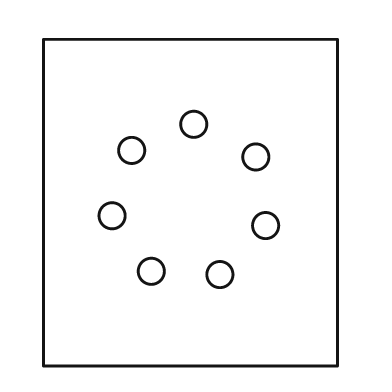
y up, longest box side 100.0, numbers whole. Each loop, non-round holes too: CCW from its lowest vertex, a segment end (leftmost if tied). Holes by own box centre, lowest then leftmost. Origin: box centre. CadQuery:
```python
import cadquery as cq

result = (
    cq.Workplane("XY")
    .moveTo(-45.0, -50.0)
    .lineTo(45.0, -50.0)
    .lineTo(45.0, 50.0)
    .lineTo(-45.0, 50.0)
    .close()
    .moveTo(9.0, -22.0)
    .circle(4.0)
    .moveTo(-12.0, -21.0)
    .circle(4.0)
    .moveTo(23.0, -7.0)
    .circle(4.0)
    .moveTo(-24.0, -4.0)
    .circle(4.0)
    .moveTo(20.0, 14.0)
    .circle(4.0)
    .moveTo(-18.0, 16.0)
    .circle(4.0)
    .moveTo(1.0, 24.0)
    .circle(4.0)
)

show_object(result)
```